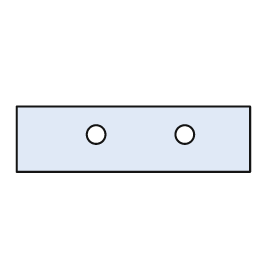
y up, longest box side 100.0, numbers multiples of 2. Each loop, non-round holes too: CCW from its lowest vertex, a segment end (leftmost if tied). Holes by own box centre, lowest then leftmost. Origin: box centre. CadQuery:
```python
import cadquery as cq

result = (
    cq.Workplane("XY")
    .moveTo(-50.0, -14.0)
    .lineTo(50.0, -14.0)
    .lineTo(50.0, 14.0)
    .lineTo(-50.0, 14.0)
    .close()
    .moveTo(-16.0, 2.0)
    .circle(4.0)
    .moveTo(22.0, 2.0)
    .circle(4.0)
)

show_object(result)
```